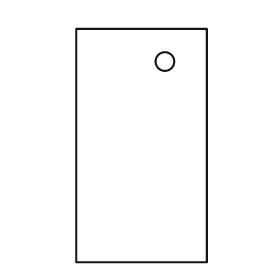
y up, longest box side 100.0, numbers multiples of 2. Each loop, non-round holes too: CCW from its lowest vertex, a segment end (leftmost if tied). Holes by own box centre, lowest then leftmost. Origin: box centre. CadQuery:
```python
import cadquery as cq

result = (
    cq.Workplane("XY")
    .moveTo(-28.0, -50.0)
    .lineTo(28.0, -50.0)
    .lineTo(28.0, 50.0)
    .lineTo(-28.0, 50.0)
    .close()
    .moveTo(10.0, 36.0)
    .circle(4.0)
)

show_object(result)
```